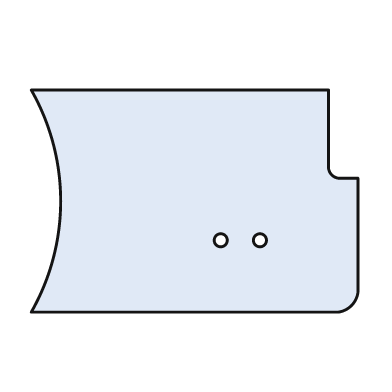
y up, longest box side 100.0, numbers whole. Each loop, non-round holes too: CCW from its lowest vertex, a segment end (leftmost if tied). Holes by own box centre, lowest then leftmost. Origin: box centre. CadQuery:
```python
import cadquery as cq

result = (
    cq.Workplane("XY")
    .moveTo(-50.0, -34.0)
    .lineTo(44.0, -34.0)
    .threePointArc((48.0, -32.0), (50.0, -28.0))
    .lineTo(50.0, 7.0)
    .lineTo(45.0, 7.0)
    .threePointArc((42.0, 8.0), (41.0, 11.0))
    .lineTo(41.0, 34.0)
    .lineTo(-50.0, 34.0)
    .threePointArc((-41.0, 0.0), (-50.0, -34.0))
    .close()
    .moveTo(8.0, -12.0)
    .circle(2.0)
    .moveTo(20.0, -12.0)
    .circle(2.0)
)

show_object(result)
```